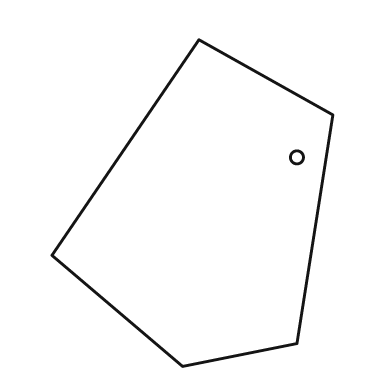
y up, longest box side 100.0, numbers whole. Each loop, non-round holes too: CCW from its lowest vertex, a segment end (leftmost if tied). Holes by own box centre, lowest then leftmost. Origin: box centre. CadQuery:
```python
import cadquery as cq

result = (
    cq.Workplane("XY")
    .moveTo(-3.0, -50.0)
    .lineTo(32.0, -43.0)
    .lineTo(43.0, 27.0)
    .lineTo(2.0, 50.0)
    .lineTo(-43.0, -16.0)
    .close()
    .moveTo(32.0, 14.0)
    .circle(2.0)
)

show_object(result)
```